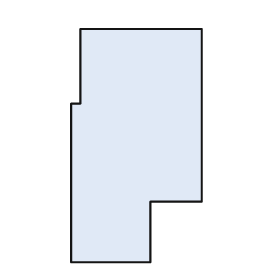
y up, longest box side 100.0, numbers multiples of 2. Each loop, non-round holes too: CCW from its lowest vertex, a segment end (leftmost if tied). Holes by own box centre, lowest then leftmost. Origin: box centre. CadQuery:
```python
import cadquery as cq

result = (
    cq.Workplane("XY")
    .moveTo(-28.0, -50.0)
    .lineTo(6.0, -50.0)
    .lineTo(6.0, -24.0)
    .lineTo(28.0, -24.0)
    .lineTo(28.0, 50.0)
    .lineTo(-24.0, 50.0)
    .lineTo(-24.0, 18.0)
    .lineTo(-28.0, 18.0)
    .close()
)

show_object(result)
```